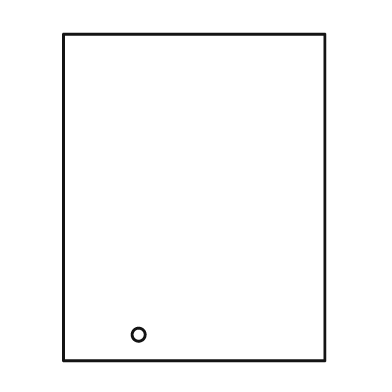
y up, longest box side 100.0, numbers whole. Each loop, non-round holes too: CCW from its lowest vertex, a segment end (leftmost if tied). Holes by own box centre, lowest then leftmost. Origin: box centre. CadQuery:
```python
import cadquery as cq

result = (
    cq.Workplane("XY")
    .moveTo(-40.0, -50.0)
    .lineTo(40.0, -50.0)
    .lineTo(40.0, 50.0)
    .lineTo(-40.0, 50.0)
    .close()
    .moveTo(-17.0, -42.0)
    .circle(2.0)
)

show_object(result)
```